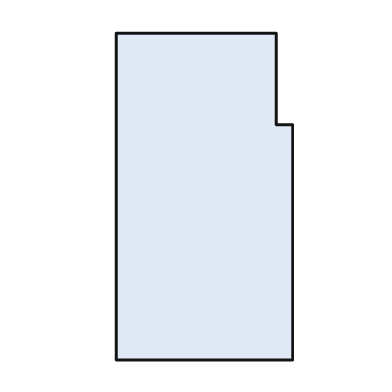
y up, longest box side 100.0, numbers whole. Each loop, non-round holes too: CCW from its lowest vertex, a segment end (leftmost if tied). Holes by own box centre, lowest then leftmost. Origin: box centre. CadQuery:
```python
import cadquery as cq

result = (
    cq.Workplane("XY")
    .moveTo(-27.0, -50.0)
    .lineTo(27.0, -50.0)
    .lineTo(27.0, 22.0)
    .lineTo(22.0, 22.0)
    .lineTo(22.0, 50.0)
    .lineTo(-27.0, 50.0)
    .close()
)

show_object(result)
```